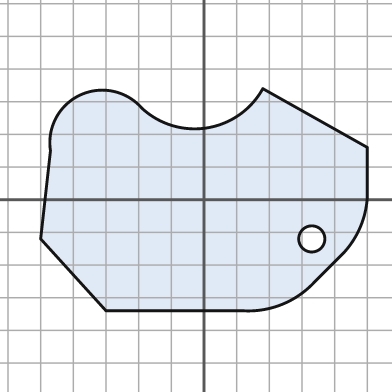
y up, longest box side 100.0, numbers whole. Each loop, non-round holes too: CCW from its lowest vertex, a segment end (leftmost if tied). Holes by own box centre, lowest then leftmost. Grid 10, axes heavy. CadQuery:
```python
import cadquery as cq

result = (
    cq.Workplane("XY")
    .moveTo(-30.0, -34.0)
    .lineTo(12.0, -34.0)
    .threePointArc((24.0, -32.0), (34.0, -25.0))
    .lineTo(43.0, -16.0)
    .threePointArc((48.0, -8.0), (50.0, 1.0))
    .lineTo(50.0, 16.0)
    .lineTo(18.0, 34.0)
    .threePointArc((1.0, 22.0), (-19.0, 28.0))
    .threePointArc((-38.0, 32.0), (-47.0, 15.0))
    .lineTo(-50.0, -12.0)
    .close()
    .moveTo(33.0, -12.0)
    .circle(4.0)
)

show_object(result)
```